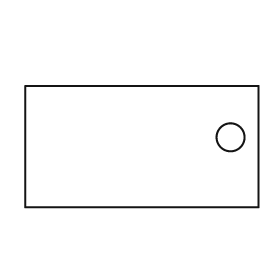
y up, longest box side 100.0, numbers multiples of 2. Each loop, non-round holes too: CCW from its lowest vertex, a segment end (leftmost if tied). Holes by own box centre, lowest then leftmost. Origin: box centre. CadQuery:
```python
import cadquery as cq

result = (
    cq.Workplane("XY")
    .moveTo(-50.0, -26.0)
    .lineTo(50.0, -26.0)
    .lineTo(50.0, 26.0)
    .lineTo(-50.0, 26.0)
    .close()
    .moveTo(38.0, 4.0)
    .circle(6.0)
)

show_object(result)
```